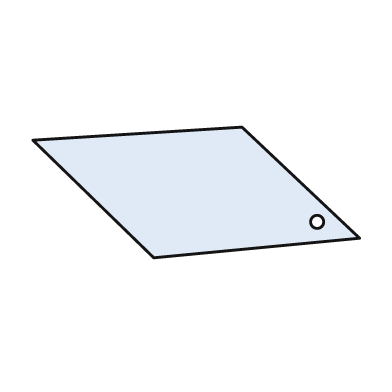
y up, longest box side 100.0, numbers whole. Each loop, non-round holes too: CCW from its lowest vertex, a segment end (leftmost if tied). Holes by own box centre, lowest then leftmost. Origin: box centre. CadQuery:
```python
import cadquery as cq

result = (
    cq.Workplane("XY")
    .moveTo(-13.0, -20.0)
    .lineTo(50.0, -14.0)
    .lineTo(14.0, 20.0)
    .lineTo(-50.0, 16.0)
    .close()
    .moveTo(37.0, -9.0)
    .circle(2.0)
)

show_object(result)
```